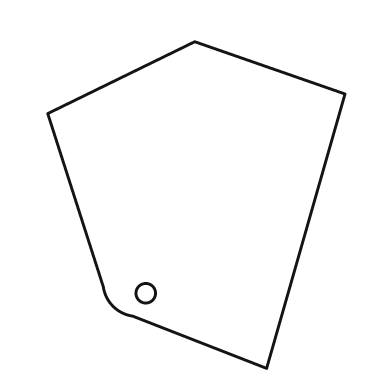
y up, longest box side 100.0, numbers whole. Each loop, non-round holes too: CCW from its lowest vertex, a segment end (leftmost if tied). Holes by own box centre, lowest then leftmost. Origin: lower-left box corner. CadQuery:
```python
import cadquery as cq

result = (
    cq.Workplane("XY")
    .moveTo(67.0, 0.0)
    .lineTo(91.0, 84.0)
    .lineTo(45.0, 100.0)
    .lineTo(0.0, 78.0)
    .lineTo(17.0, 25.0)
    .threePointArc((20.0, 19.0), (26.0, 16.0))
    .close()
    .moveTo(30.0, 23.0)
    .circle(3.0)
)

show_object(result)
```